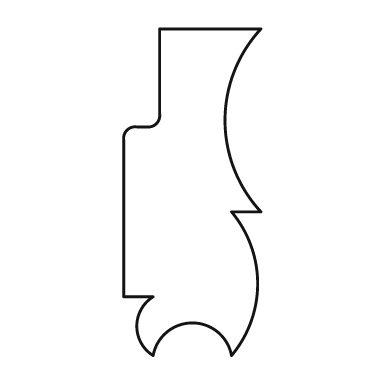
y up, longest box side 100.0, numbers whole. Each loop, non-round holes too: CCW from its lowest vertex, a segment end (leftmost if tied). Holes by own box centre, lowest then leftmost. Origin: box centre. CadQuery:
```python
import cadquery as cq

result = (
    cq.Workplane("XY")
    .moveTo(-12.0, -50.0)
    .threePointArc((0.0, -40.0), (12.0, -50.0))
    .threePointArc((20.0, -28.0), (12.0, -6.0))
    .lineTo(21.0, -6.0)
    .threePointArc((10.0, 22.0), (21.0, 50.0))
    .lineTo(-10.0, 50.0)
    .lineTo(-10.0, 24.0)
    .threePointArc((-11.0, 21.0), (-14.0, 20.0))
    .lineTo(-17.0, 20.0)
    .threePointArc((-20.0, 19.0), (-21.0, 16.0))
    .lineTo(-21.0, -32.0)
    .lineTo(-12.0, -32.0)
    .threePointArc((-17.0, -41.0), (-12.0, -50.0))
    .close()
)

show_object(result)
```